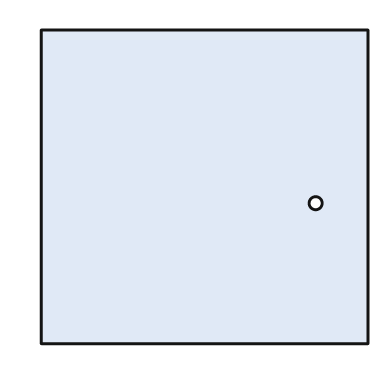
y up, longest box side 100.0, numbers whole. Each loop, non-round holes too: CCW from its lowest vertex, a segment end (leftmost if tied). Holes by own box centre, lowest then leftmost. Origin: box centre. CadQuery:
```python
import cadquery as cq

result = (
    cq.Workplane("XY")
    .moveTo(-50.0, -48.0)
    .lineTo(50.0, -48.0)
    .lineTo(50.0, 48.0)
    .lineTo(-50.0, 48.0)
    .close()
    .moveTo(34.0, -5.0)
    .circle(2.0)
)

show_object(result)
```